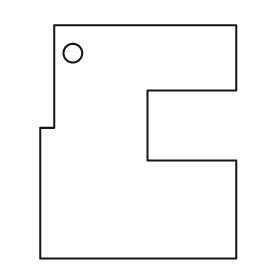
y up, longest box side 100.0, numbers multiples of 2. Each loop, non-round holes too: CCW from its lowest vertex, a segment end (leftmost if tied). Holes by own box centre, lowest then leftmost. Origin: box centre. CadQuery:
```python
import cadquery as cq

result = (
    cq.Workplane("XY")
    .moveTo(-42.0, -50.0)
    .lineTo(42.0, -50.0)
    .lineTo(42.0, -8.0)
    .lineTo(4.0, -8.0)
    .lineTo(4.0, 22.0)
    .lineTo(42.0, 22.0)
    .lineTo(42.0, 50.0)
    .lineTo(-36.0, 50.0)
    .lineTo(-36.0, 6.0)
    .lineTo(-42.0, 6.0)
    .close()
    .moveTo(-28.0, 38.0)
    .circle(4.0)
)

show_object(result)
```